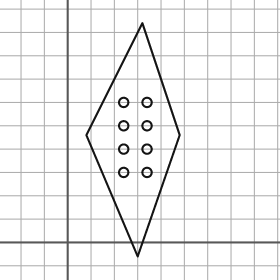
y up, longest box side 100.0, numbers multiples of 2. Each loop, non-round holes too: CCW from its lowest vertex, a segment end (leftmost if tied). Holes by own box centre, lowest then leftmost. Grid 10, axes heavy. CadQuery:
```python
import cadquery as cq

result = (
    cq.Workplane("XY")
    .moveTo(30.0, -6.0)
    .lineTo(48.0, 46.0)
    .lineTo(32.0, 94.0)
    .lineTo(8.0, 46.0)
    .close()
    .moveTo(24.0, 30.0)
    .circle(2.0)
    .moveTo(34.0, 30.0)
    .circle(2.0)
    .moveTo(24.0, 40.0)
    .circle(2.0)
    .moveTo(34.0, 40.0)
    .circle(2.0)
    .moveTo(24.0, 50.0)
    .circle(2.0)
    .moveTo(34.0, 50.0)
    .circle(2.0)
    .moveTo(24.0, 60.0)
    .circle(2.0)
    .moveTo(34.0, 60.0)
    .circle(2.0)
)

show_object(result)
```